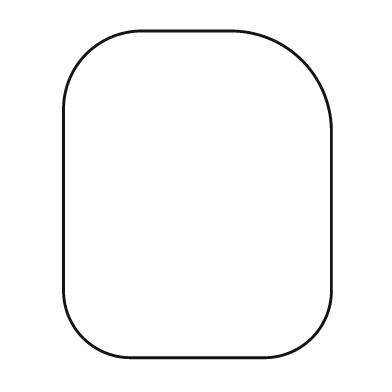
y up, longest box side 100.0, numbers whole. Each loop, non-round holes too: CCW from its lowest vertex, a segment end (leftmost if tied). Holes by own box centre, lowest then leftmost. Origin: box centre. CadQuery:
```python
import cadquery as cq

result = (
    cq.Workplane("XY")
    .moveTo(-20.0, -50.0)
    .lineTo(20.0, -50.0)
    .threePointArc((35.0, -44.0), (41.0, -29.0))
    .lineTo(41.0, 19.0)
    .threePointArc((32.0, 41.0), (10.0, 50.0))
    .lineTo(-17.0, 50.0)
    .threePointArc((-34.0, 43.0), (-41.0, 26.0))
    .lineTo(-41.0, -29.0)
    .threePointArc((-35.0, -44.0), (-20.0, -50.0))
    .close()
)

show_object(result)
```